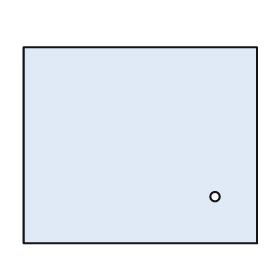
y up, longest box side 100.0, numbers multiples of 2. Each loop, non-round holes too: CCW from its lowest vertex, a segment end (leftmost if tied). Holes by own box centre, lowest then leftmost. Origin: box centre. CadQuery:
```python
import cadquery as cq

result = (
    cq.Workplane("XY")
    .moveTo(-50.0, -42.0)
    .lineTo(50.0, -42.0)
    .lineTo(50.0, 42.0)
    .lineTo(-50.0, 42.0)
    .close()
    .moveTo(32.0, -22.0)
    .circle(2.0)
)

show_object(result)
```